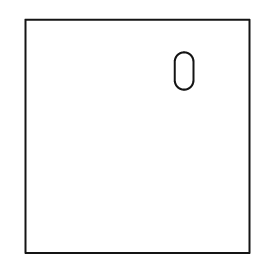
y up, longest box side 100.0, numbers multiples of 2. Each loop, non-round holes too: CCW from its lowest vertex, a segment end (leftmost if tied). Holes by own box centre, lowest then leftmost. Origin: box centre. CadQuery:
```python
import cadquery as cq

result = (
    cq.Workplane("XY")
    .moveTo(-48.0, -50.0)
    .lineTo(48.0, -50.0)
    .lineTo(48.0, 50.0)
    .lineTo(-48.0, 50.0)
    .close()
    .moveTo(16.0, 24.0)
    .threePointArc((20.0, 20.0), (24.0, 24.0))
    .lineTo(24.0, 32.0)
    .threePointArc((20.0, 36.0), (16.0, 32.0))
    .close()
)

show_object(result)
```